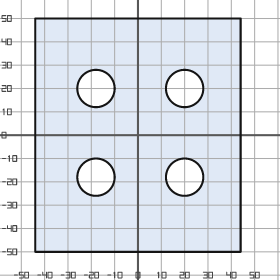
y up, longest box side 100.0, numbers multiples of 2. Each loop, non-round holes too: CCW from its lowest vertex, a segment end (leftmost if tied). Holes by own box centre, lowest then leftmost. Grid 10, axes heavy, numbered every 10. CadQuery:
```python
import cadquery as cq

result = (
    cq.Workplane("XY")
    .moveTo(-44.0, -50.0)
    .lineTo(44.0, -50.0)
    .lineTo(44.0, 50.0)
    .lineTo(-44.0, 50.0)
    .close()
    .moveTo(-18.0, -18.0)
    .circle(8.0)
    .moveTo(20.0, -18.0)
    .circle(8.0)
    .moveTo(-18.0, 20.0)
    .circle(8.0)
    .moveTo(20.0, 20.0)
    .circle(8.0)
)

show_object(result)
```